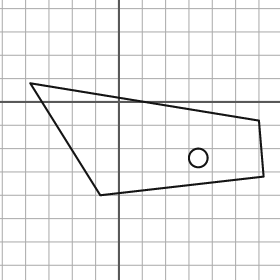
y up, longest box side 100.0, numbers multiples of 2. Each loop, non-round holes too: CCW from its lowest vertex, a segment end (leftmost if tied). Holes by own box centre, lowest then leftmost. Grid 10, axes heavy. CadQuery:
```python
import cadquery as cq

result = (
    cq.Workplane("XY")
    .moveTo(-8.0, -40.0)
    .lineTo(62.0, -32.0)
    .lineTo(60.0, -8.0)
    .lineTo(-38.0, 8.0)
    .close()
    .moveTo(34.0, -24.0)
    .circle(4.0)
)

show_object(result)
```